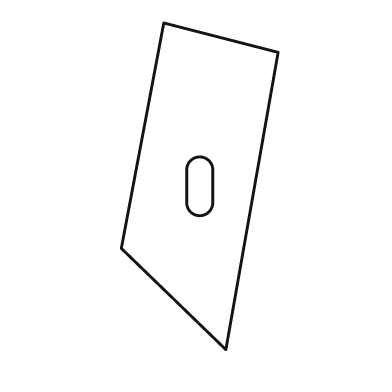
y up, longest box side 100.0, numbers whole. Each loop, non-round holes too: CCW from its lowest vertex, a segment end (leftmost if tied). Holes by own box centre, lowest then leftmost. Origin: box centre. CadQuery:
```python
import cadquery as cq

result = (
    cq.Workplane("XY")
    .moveTo(8.0, -50.0)
    .lineTo(24.0, 41.0)
    .lineTo(-11.0, 50.0)
    .lineTo(-24.0, -19.0)
    .close()
    .moveTo(-4.0, -5.0)
    .threePointArc((0.0, -9.0), (4.0, -5.0))
    .lineTo(4.0, 5.0)
    .threePointArc((0.0, 9.0), (-4.0, 5.0))
    .close()
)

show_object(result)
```